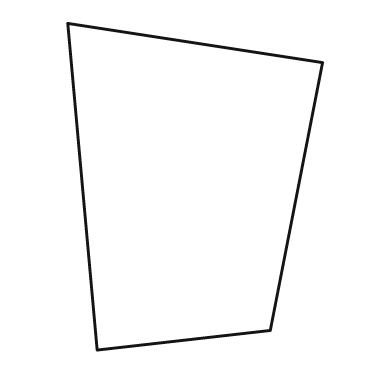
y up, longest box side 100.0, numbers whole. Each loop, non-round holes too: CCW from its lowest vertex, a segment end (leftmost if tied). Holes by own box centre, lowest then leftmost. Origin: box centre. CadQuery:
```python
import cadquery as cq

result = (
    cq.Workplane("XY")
    .moveTo(-30.0, -50.0)
    .lineTo(23.0, -44.0)
    .lineTo(39.0, 38.0)
    .lineTo(-39.0, 50.0)
    .close()
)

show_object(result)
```